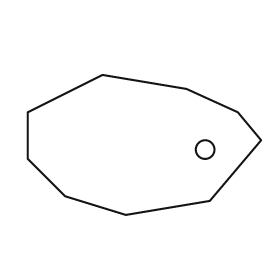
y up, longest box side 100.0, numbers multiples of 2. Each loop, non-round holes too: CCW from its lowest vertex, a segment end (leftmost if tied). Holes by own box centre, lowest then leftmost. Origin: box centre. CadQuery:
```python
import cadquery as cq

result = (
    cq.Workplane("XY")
    .moveTo(-8.0, -30.0)
    .lineTo(28.0, -24.0)
    .lineTo(50.0, 2.0)
    .lineTo(40.0, 14.0)
    .lineTo(18.0, 24.0)
    .lineTo(-18.0, 30.0)
    .lineTo(-50.0, 14.0)
    .lineTo(-50.0, -6.0)
    .lineTo(-34.0, -22.0)
    .close()
    .moveTo(26.0, -2.0)
    .circle(4.0)
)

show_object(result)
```